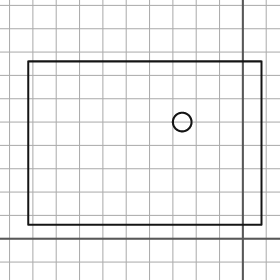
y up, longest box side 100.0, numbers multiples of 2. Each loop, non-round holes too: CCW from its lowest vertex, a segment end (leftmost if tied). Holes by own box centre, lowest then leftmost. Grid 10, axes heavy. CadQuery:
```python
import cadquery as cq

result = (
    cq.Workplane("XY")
    .moveTo(-92.0, 6.0)
    .lineTo(8.0, 6.0)
    .lineTo(8.0, 76.0)
    .lineTo(-92.0, 76.0)
    .close()
    .moveTo(-26.0, 50.0)
    .circle(4.0)
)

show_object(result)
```